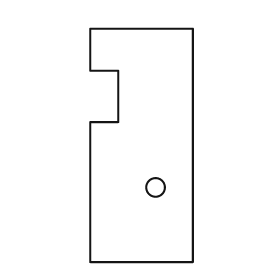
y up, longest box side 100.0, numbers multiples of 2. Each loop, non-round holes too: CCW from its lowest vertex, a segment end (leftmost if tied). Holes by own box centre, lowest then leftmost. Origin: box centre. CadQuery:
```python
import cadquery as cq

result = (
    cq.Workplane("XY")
    .moveTo(-22.0, -50.0)
    .lineTo(22.0, -50.0)
    .lineTo(22.0, 50.0)
    .lineTo(-22.0, 50.0)
    .lineTo(-22.0, 32.0)
    .lineTo(-10.0, 32.0)
    .lineTo(-10.0, 10.0)
    .lineTo(-22.0, 10.0)
    .close()
    .moveTo(6.0, -18.0)
    .circle(4.0)
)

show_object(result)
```